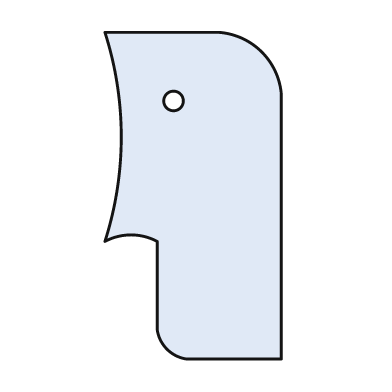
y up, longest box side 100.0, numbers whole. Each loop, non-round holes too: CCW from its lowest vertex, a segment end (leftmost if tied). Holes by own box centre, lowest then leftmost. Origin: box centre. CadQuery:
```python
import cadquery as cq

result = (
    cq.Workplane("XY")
    .moveTo(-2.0, -50.0)
    .lineTo(27.0, -50.0)
    .lineTo(27.0, 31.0)
    .threePointArc((21.0, 44.0), (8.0, 50.0))
    .lineTo(-27.0, 50.0)
    .threePointArc((-22.0, 18.0), (-27.0, -14.0))
    .threePointArc((-19.0, -12.0), (-11.0, -14.0))
    .lineTo(-11.0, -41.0)
    .threePointArc((-8.0, -47.0), (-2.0, -50.0))
    .close()
    .moveTo(-6.0, 29.0)
    .circle(3.0)
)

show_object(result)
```